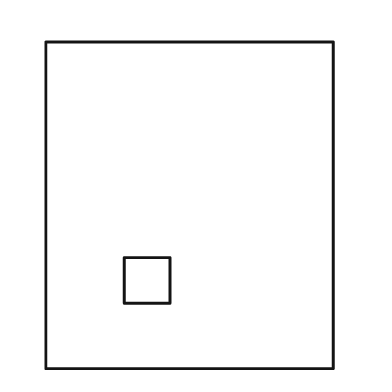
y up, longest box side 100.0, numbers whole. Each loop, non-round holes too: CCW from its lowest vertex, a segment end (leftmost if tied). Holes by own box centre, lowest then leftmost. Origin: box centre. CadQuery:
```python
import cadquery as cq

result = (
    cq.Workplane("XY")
    .moveTo(-44.0, -50.0)
    .lineTo(44.0, -50.0)
    .lineTo(44.0, 50.0)
    .lineTo(-44.0, 50.0)
    .close()
    .moveTo(-20.0, -30.0)
    .lineTo(-6.0, -30.0)
    .lineTo(-6.0, -16.0)
    .lineTo(-20.0, -16.0)
    .close()
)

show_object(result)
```